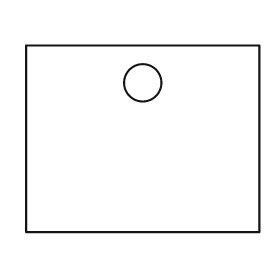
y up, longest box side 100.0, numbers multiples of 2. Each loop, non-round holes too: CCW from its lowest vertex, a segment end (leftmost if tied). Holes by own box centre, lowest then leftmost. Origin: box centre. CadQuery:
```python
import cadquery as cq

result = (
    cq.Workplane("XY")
    .moveTo(-50.0, -40.0)
    .lineTo(50.0, -40.0)
    .lineTo(50.0, 40.0)
    .lineTo(-50.0, 40.0)
    .close()
    .moveTo(0.0, 24.0)
    .circle(8.0)
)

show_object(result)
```